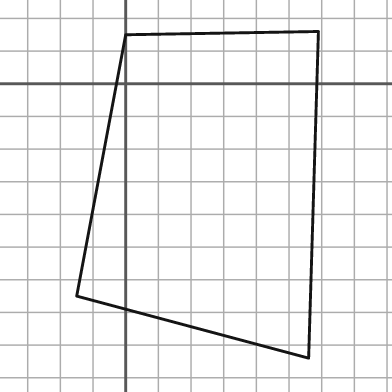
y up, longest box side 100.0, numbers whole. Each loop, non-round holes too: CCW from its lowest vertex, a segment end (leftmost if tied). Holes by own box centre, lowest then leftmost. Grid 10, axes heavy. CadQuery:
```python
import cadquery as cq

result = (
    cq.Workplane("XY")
    .moveTo(56.0, -84.0)
    .lineTo(59.0, 16.0)
    .lineTo(0.0, 15.0)
    .lineTo(-15.0, -65.0)
    .close()
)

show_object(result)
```